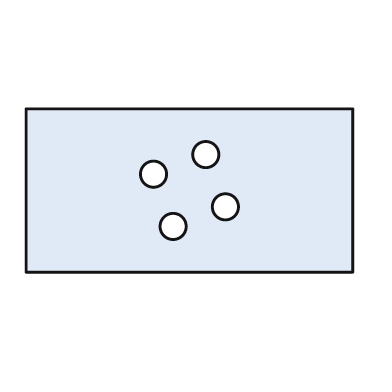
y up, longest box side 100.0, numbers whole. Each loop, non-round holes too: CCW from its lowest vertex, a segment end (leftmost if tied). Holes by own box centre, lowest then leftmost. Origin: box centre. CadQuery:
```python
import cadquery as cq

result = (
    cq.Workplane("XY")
    .moveTo(-50.0, -25.0)
    .lineTo(50.0, -25.0)
    .lineTo(50.0, 25.0)
    .lineTo(-50.0, 25.0)
    .close()
    .moveTo(-5.0, -11.0)
    .circle(4.0)
    .moveTo(11.0, -5.0)
    .circle(4.0)
    .moveTo(-11.0, 5.0)
    .circle(4.0)
    .moveTo(5.0, 11.0)
    .circle(4.0)
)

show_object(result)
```